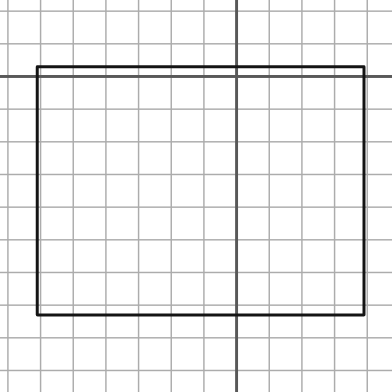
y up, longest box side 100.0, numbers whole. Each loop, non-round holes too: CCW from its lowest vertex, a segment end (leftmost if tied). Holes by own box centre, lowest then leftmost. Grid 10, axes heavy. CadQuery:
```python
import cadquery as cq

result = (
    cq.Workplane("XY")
    .moveTo(-61.0, -73.0)
    .lineTo(39.0, -73.0)
    .lineTo(39.0, 3.0)
    .lineTo(-61.0, 3.0)
    .close()
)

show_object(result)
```